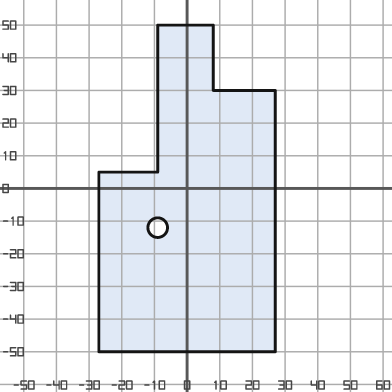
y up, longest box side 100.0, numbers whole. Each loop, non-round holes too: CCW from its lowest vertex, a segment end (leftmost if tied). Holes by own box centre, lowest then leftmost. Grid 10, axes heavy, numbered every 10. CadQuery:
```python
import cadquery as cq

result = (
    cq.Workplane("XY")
    .moveTo(-27.0, -50.0)
    .lineTo(27.0, -50.0)
    .lineTo(27.0, 30.0)
    .lineTo(8.0, 30.0)
    .lineTo(8.0, 50.0)
    .lineTo(-9.0, 50.0)
    .lineTo(-9.0, 5.0)
    .lineTo(-27.0, 5.0)
    .close()
    .moveTo(-9.0, -12.0)
    .circle(3.0)
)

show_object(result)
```